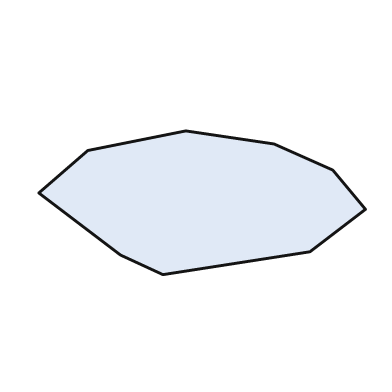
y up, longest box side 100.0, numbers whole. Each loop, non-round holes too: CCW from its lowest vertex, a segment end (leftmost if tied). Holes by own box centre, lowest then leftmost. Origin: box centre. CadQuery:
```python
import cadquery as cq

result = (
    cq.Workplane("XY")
    .moveTo(-12.0, -22.0)
    .lineTo(33.0, -15.0)
    .lineTo(50.0, -2.0)
    .lineTo(40.0, 10.0)
    .lineTo(22.0, 18.0)
    .lineTo(-5.0, 22.0)
    .lineTo(-35.0, 16.0)
    .lineTo(-50.0, 3.0)
    .lineTo(-25.0, -16.0)
    .close()
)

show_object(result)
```